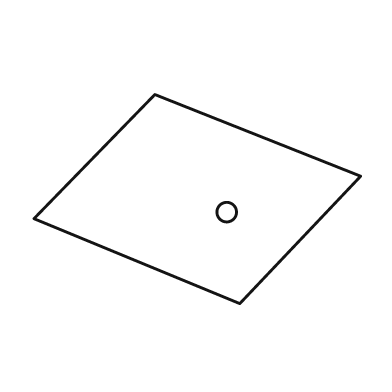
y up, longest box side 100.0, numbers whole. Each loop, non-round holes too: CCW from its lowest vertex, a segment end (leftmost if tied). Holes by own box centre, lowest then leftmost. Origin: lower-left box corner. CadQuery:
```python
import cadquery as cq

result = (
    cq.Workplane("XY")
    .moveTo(63.0, 0.0)
    .lineTo(100.0, 39.0)
    .lineTo(37.0, 64.0)
    .lineTo(0.0, 26.0)
    .close()
    .moveTo(59.0, 28.0)
    .circle(3.0)
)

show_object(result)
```